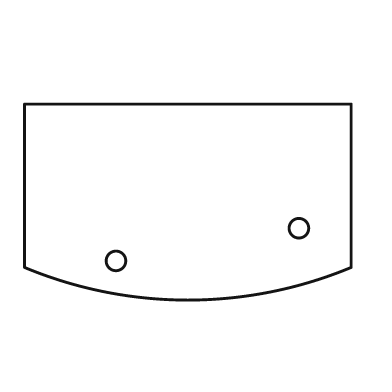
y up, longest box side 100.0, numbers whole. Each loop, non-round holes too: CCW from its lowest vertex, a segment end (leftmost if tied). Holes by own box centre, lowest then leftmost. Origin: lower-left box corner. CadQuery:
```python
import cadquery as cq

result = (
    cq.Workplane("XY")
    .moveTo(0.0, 10.0)
    .threePointArc((50.0, 0.0), (100.0, 10.0))
    .lineTo(100.0, 60.0)
    .lineTo(0.0, 60.0)
    .close()
    .moveTo(28.0, 12.0)
    .circle(3.0)
    .moveTo(84.0, 22.0)
    .circle(3.0)
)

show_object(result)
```